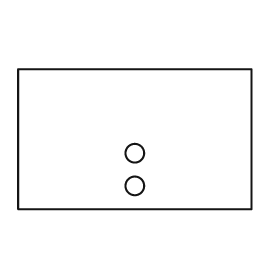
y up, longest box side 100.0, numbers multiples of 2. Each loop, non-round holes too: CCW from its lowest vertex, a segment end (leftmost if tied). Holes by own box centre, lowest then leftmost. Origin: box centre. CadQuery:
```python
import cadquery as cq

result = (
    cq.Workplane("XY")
    .moveTo(-50.0, -30.0)
    .lineTo(50.0, -30.0)
    .lineTo(50.0, 30.0)
    .lineTo(-50.0, 30.0)
    .close()
    .moveTo(0.0, -20.0)
    .circle(4.0)
    .moveTo(0.0, -6.0)
    .circle(4.0)
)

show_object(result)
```